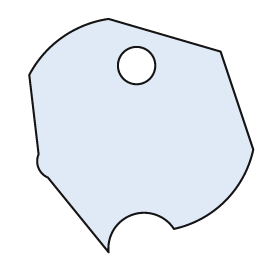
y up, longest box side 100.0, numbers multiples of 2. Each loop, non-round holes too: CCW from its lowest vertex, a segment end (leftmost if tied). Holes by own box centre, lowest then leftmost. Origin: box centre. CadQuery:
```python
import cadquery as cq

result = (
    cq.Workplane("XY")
    .moveTo(-14.0, -50.0)
    .threePointArc((-4.0, -34.0), (14.0, -40.0))
    .threePointArc((36.0, -28.0), (48.0, -6.0))
    .lineTo(34.0, 36.0)
    .lineTo(-14.0, 50.0)
    .threePointArc((-34.0, 42.0), (-48.0, 26.0))
    .lineTo(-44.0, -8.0)
    .threePointArc((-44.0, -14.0), (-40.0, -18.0))
    .close()
    .moveTo(-2.0, 30.0)
    .circle(8.0)
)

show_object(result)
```